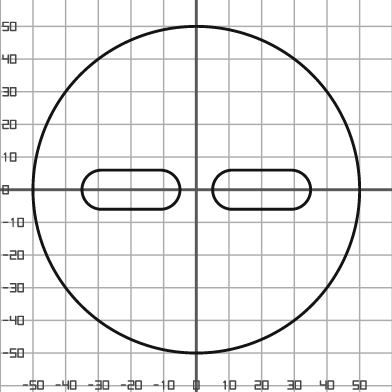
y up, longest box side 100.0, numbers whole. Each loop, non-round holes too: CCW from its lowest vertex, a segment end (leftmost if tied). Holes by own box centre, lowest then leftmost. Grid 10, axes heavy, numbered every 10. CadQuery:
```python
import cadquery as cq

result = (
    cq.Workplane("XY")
    .moveTo(0.0, 0.0)
    .circle(50.0)
    .moveTo(-29.0, -6.0)
    .lineTo(-11.0, -6.0)
    .threePointArc((-5.0, 0.0), (-11.0, 6.0))
    .lineTo(-29.0, 6.0)
    .threePointArc((-35.0, 0.0), (-29.0, -6.0))
    .close()
    .moveTo(11.0, -6.0)
    .lineTo(29.0, -6.0)
    .threePointArc((35.0, 0.0), (29.0, 6.0))
    .lineTo(11.0, 6.0)
    .threePointArc((5.0, 0.0), (11.0, -6.0))
    .close()
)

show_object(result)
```